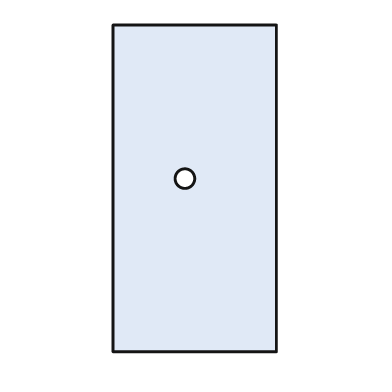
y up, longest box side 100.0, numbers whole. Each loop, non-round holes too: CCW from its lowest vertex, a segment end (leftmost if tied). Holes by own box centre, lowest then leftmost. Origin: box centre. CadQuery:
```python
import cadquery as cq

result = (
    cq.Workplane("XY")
    .moveTo(-25.0, -50.0)
    .lineTo(25.0, -50.0)
    .lineTo(25.0, 50.0)
    .lineTo(-25.0, 50.0)
    .close()
    .moveTo(-3.0, 3.0)
    .circle(3.0)
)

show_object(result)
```